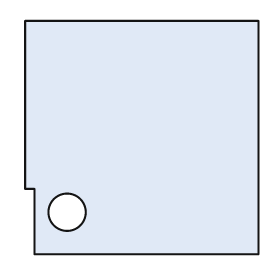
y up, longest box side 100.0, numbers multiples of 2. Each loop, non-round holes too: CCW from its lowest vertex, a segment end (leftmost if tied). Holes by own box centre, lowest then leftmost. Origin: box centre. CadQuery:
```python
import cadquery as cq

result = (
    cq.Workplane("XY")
    .moveTo(-46.0, -50.0)
    .lineTo(50.0, -50.0)
    .lineTo(50.0, 50.0)
    .lineTo(-50.0, 50.0)
    .lineTo(-50.0, -22.0)
    .lineTo(-46.0, -22.0)
    .close()
    .moveTo(-32.0, -32.0)
    .circle(8.0)
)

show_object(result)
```